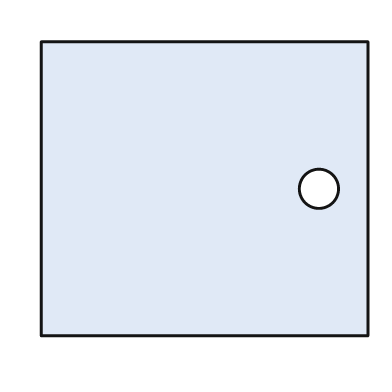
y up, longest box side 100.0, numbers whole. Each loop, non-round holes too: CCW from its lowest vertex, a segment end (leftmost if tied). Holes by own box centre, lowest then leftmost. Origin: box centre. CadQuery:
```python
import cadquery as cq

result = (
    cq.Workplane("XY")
    .moveTo(-50.0, -45.0)
    .lineTo(50.0, -45.0)
    .lineTo(50.0, 45.0)
    .lineTo(-50.0, 45.0)
    .close()
    .moveTo(35.0, 0.0)
    .circle(6.0)
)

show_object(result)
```